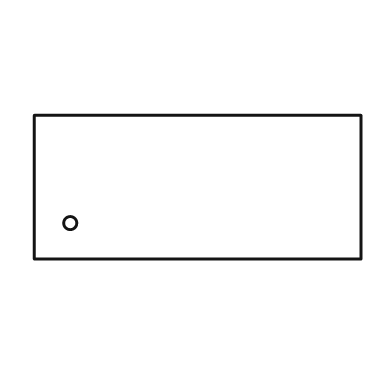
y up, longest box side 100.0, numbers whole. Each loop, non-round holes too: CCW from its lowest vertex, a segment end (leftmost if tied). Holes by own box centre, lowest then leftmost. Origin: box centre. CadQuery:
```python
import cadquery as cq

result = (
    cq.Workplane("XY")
    .moveTo(-50.0, -22.0)
    .lineTo(50.0, -22.0)
    .lineTo(50.0, 22.0)
    .lineTo(-50.0, 22.0)
    .close()
    .moveTo(-39.0, -11.0)
    .circle(2.0)
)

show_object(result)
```